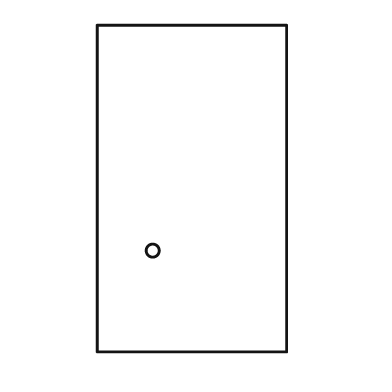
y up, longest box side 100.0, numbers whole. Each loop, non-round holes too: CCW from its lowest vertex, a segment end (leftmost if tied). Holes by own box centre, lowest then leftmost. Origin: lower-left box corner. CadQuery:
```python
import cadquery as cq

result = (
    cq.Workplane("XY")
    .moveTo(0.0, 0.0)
    .lineTo(58.0, 0.0)
    .lineTo(58.0, 100.0)
    .lineTo(0.0, 100.0)
    .close()
    .moveTo(17.0, 31.0)
    .circle(2.0)
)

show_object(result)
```